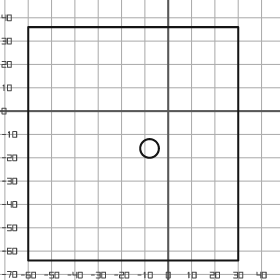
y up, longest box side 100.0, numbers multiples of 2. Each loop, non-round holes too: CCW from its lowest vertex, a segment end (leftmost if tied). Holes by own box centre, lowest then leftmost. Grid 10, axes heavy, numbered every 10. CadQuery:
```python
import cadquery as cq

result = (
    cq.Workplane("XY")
    .moveTo(-60.0, -64.0)
    .lineTo(30.0, -64.0)
    .lineTo(30.0, 36.0)
    .lineTo(-60.0, 36.0)
    .close()
    .moveTo(-8.0, -16.0)
    .circle(4.0)
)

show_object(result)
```